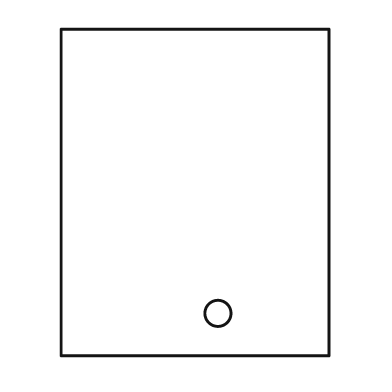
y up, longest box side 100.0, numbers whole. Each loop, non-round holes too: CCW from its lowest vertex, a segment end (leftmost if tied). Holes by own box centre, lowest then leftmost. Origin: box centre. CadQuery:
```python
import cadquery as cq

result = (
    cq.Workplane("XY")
    .moveTo(-41.0, -50.0)
    .lineTo(41.0, -50.0)
    .lineTo(41.0, 50.0)
    .lineTo(-41.0, 50.0)
    .close()
    .moveTo(7.0, -37.0)
    .circle(4.0)
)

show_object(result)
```